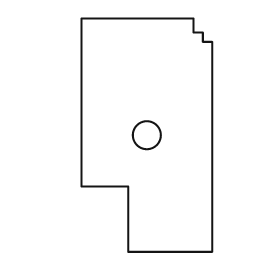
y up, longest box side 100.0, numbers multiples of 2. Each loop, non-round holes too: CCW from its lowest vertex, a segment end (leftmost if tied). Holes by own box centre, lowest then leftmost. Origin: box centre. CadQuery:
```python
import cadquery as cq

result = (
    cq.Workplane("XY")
    .moveTo(-8.0, -50.0)
    .lineTo(28.0, -50.0)
    .lineTo(28.0, 40.0)
    .lineTo(24.0, 40.0)
    .lineTo(24.0, 44.0)
    .lineTo(20.0, 44.0)
    .lineTo(20.0, 50.0)
    .lineTo(-28.0, 50.0)
    .lineTo(-28.0, -22.0)
    .lineTo(-8.0, -22.0)
    .close()
    .moveTo(0.0, 0.0)
    .circle(6.0)
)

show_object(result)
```